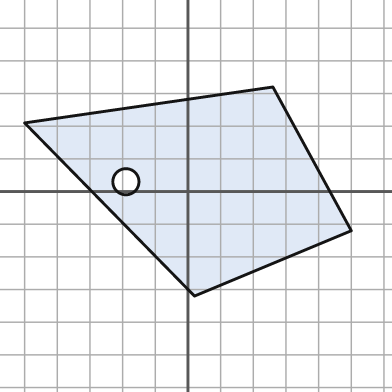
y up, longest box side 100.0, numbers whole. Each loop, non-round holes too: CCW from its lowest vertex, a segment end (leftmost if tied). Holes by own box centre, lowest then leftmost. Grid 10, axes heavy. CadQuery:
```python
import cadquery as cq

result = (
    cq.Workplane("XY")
    .moveTo(2.0, -32.0)
    .lineTo(50.0, -12.0)
    .lineTo(26.0, 32.0)
    .lineTo(-50.0, 21.0)
    .close()
    .moveTo(-19.0, 3.0)
    .circle(4.0)
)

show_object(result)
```